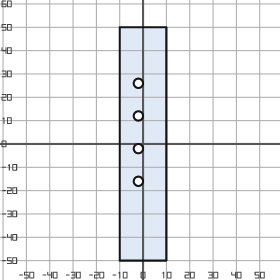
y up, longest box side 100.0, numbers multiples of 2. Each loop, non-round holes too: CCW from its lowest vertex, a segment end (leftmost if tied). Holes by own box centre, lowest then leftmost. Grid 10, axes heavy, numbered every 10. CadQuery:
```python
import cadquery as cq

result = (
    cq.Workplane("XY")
    .moveTo(-10.0, -50.0)
    .lineTo(10.0, -50.0)
    .lineTo(10.0, 50.0)
    .lineTo(-10.0, 50.0)
    .close()
    .moveTo(-2.0, -16.0)
    .circle(2.0)
    .moveTo(-2.0, -2.0)
    .circle(2.0)
    .moveTo(-2.0, 12.0)
    .circle(2.0)
    .moveTo(-2.0, 26.0)
    .circle(2.0)
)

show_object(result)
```